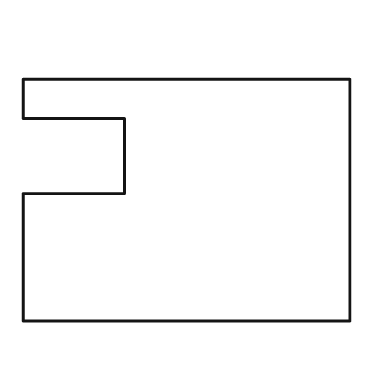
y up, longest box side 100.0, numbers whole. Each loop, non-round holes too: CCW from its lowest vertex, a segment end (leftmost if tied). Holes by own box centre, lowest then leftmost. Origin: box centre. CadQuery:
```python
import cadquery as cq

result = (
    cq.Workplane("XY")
    .moveTo(-50.0, -37.0)
    .lineTo(50.0, -37.0)
    .lineTo(50.0, 37.0)
    .lineTo(-50.0, 37.0)
    .lineTo(-50.0, 25.0)
    .lineTo(-19.0, 25.0)
    .lineTo(-19.0, 2.0)
    .lineTo(-50.0, 2.0)
    .close()
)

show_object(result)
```